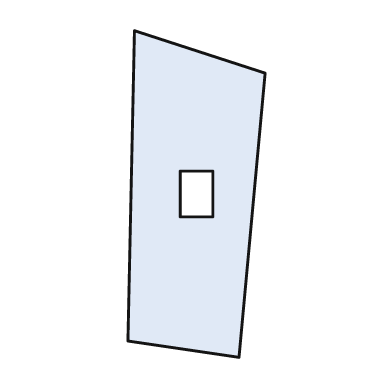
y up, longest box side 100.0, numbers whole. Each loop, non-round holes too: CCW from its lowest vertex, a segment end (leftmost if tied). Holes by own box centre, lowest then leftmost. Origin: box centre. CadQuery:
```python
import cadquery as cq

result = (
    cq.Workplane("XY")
    .moveTo(13.0, -50.0)
    .lineTo(21.0, 37.0)
    .lineTo(-19.0, 50.0)
    .lineTo(-21.0, -45.0)
    .close()
    .moveTo(-5.0, -7.0)
    .lineTo(5.0, -7.0)
    .lineTo(5.0, 7.0)
    .lineTo(-5.0, 7.0)
    .close()
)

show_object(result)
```